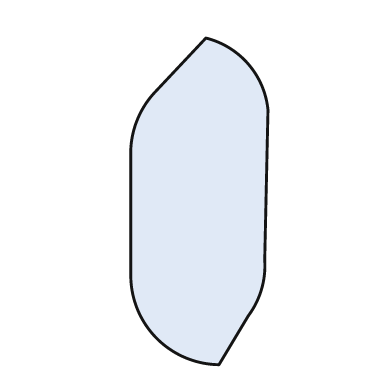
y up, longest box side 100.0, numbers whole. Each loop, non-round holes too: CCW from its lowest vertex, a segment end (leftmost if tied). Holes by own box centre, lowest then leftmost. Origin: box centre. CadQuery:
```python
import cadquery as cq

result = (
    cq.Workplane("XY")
    .moveTo(6.0, -50.0)
    .lineTo(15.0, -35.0)
    .threePointArc((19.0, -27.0), (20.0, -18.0))
    .lineTo(21.0, 28.0)
    .threePointArc((15.0, 42.0), (2.0, 50.0))
    .lineTo(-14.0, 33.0)
    .threePointArc((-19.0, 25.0), (-21.0, 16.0))
    .lineTo(-21.0, -23.0)
    .threePointArc((-13.0, -42.0), (6.0, -50.0))
    .close()
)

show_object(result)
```